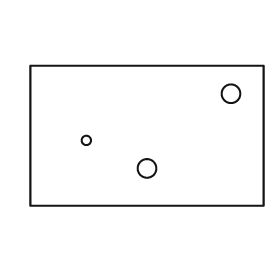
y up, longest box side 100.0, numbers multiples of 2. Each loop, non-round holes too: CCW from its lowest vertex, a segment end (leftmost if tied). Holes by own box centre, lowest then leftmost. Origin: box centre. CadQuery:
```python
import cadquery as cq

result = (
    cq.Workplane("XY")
    .moveTo(-50.0, -30.0)
    .lineTo(50.0, -30.0)
    .lineTo(50.0, 30.0)
    .lineTo(-50.0, 30.0)
    .close()
    .moveTo(0.0, -14.0)
    .circle(4.0)
    .moveTo(-26.0, -2.0)
    .circle(2.0)
    .moveTo(36.0, 18.0)
    .circle(4.0)
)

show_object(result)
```